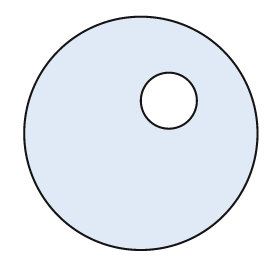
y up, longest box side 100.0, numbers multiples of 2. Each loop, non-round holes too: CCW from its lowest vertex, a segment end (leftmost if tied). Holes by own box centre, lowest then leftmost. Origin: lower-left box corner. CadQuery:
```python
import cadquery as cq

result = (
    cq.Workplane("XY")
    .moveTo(50.0, 50.0)
    .circle(50.0)
    .moveTo(62.0, 64.0)
    .circle(12.0)
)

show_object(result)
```